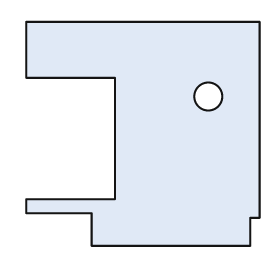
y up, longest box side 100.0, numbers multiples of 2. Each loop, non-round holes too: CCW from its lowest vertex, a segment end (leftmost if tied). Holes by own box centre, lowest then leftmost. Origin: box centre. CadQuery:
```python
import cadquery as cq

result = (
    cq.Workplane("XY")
    .moveTo(-22.0, -48.0)
    .lineTo(46.0, -48.0)
    .lineTo(46.0, -36.0)
    .lineTo(50.0, -36.0)
    .lineTo(50.0, 48.0)
    .lineTo(-50.0, 48.0)
    .lineTo(-50.0, 24.0)
    .lineTo(-12.0, 24.0)
    .lineTo(-12.0, -28.0)
    .lineTo(-50.0, -28.0)
    .lineTo(-50.0, -34.0)
    .lineTo(-22.0, -34.0)
    .close()
    .moveTo(28.0, 16.0)
    .circle(6.0)
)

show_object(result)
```